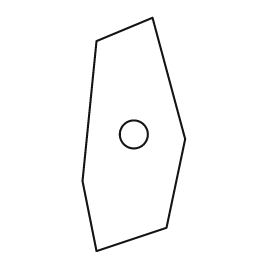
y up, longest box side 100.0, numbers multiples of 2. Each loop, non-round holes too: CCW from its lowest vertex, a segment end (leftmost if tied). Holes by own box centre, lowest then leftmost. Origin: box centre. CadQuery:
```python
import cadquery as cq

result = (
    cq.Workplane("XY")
    .moveTo(-16.0, -50.0)
    .lineTo(14.0, -40.0)
    .lineTo(22.0, -2.0)
    .lineTo(8.0, 50.0)
    .lineTo(-16.0, 40.0)
    .lineTo(-22.0, -20.0)
    .close()
    .moveTo(0.0, 0.0)
    .circle(6.0)
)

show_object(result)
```